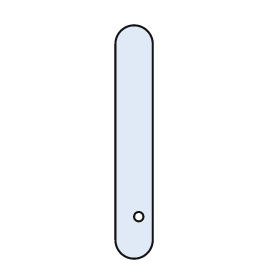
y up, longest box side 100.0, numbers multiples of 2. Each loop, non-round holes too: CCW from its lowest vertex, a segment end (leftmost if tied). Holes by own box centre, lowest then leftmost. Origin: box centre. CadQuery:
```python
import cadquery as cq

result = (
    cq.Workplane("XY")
    .moveTo(-8.0, -42.0)
    .threePointArc((0.0, -50.0), (8.0, -42.0))
    .lineTo(8.0, 42.0)
    .threePointArc((0.0, 50.0), (-8.0, 42.0))
    .close()
    .moveTo(2.0, -32.0)
    .circle(2.0)
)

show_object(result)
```